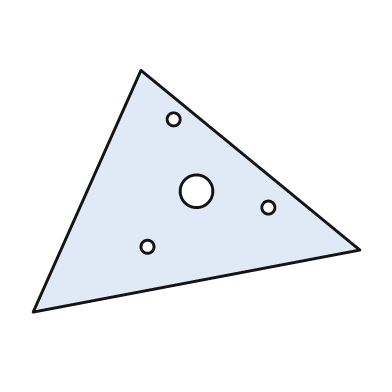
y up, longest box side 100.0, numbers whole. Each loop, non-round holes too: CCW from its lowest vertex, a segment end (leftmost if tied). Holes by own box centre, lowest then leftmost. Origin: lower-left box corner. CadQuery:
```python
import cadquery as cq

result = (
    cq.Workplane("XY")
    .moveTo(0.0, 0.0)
    .lineTo(100.0, 19.0)
    .lineTo(33.0, 74.0)
    .close()
    .moveTo(35.0, 20.0)
    .circle(2.0)
    .moveTo(72.0, 32.0)
    .circle(2.0)
    .moveTo(50.0, 37.0)
    .circle(5.0)
    .moveTo(43.0, 59.0)
    .circle(2.0)
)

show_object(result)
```